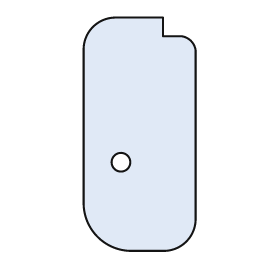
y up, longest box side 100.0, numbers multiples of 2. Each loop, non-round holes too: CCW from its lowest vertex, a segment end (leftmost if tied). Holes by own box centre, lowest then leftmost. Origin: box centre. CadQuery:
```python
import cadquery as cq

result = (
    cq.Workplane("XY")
    .moveTo(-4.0, -50.0)
    .lineTo(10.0, -50.0)
    .threePointArc((20.0, -46.0), (24.0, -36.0))
    .lineTo(24.0, 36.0)
    .threePointArc((22.0, 40.0), (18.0, 42.0))
    .lineTo(10.0, 42.0)
    .lineTo(10.0, 50.0)
    .lineTo(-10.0, 50.0)
    .threePointArc((-20.0, 46.0), (-24.0, 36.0))
    .lineTo(-24.0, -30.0)
    .threePointArc((-18.0, -44.0), (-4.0, -50.0))
    .close()
    .moveTo(-8.0, -12.0)
    .circle(4.0)
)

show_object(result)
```